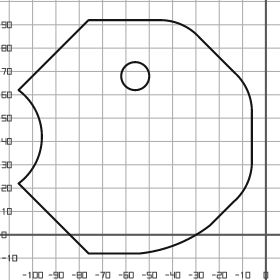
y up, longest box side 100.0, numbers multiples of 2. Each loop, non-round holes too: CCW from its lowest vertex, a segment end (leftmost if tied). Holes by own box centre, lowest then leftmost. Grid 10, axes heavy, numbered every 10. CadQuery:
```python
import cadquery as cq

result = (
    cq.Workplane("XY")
    .moveTo(-76.0, -8.0)
    .lineTo(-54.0, -8.0)
    .threePointArc((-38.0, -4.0), (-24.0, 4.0))
    .lineTo(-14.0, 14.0)
    .threePointArc((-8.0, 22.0), (-6.0, 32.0))
    .lineTo(-6.0, 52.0)
    .threePointArc((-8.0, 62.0), (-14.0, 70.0))
    .lineTo(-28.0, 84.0)
    .threePointArc((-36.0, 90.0), (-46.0, 92.0))
    .lineTo(-76.0, 92.0)
    .lineTo(-106.0, 62.0)
    .threePointArc((-96.0, 42.0), (-106.0, 22.0))
    .close()
    .moveTo(-56.0, 68.0)
    .circle(6.0)
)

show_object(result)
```